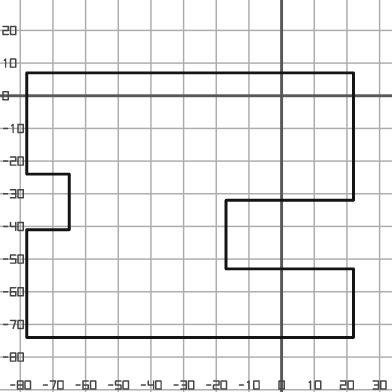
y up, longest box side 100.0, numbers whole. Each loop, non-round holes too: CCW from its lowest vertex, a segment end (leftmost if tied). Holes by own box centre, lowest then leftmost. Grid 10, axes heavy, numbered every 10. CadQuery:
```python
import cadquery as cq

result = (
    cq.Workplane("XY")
    .moveTo(-78.0, -74.0)
    .lineTo(22.0, -74.0)
    .lineTo(22.0, -53.0)
    .lineTo(-17.0, -53.0)
    .lineTo(-17.0, -32.0)
    .lineTo(22.0, -32.0)
    .lineTo(22.0, 7.0)
    .lineTo(-78.0, 7.0)
    .lineTo(-78.0, -24.0)
    .lineTo(-65.0, -24.0)
    .lineTo(-65.0, -41.0)
    .lineTo(-78.0, -41.0)
    .close()
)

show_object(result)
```